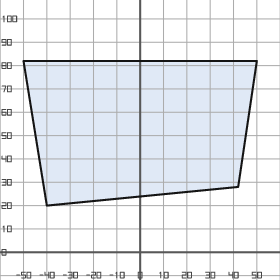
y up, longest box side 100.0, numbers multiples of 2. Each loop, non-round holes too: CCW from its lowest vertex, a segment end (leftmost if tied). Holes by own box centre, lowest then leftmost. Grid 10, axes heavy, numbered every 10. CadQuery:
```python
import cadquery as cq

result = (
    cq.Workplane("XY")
    .moveTo(-40.0, 20.0)
    .lineTo(42.0, 28.0)
    .lineTo(50.0, 82.0)
    .lineTo(-50.0, 82.0)
    .close()
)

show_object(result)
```